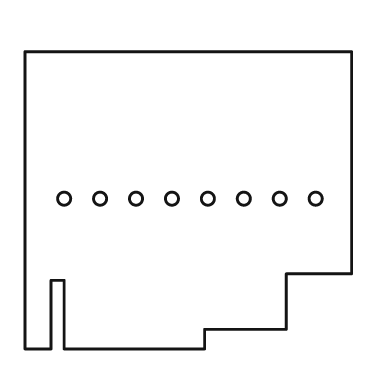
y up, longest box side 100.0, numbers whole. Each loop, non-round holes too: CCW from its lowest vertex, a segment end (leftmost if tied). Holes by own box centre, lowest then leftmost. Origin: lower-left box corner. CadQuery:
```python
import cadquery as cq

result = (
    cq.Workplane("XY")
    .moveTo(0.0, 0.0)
    .lineTo(8.0, 0.0)
    .lineTo(8.0, 21.0)
    .lineTo(12.0, 21.0)
    .lineTo(12.0, 0.0)
    .lineTo(55.0, 0.0)
    .lineTo(55.0, 6.0)
    .lineTo(80.0, 6.0)
    .lineTo(80.0, 23.0)
    .lineTo(100.0, 23.0)
    .lineTo(100.0, 91.0)
    .lineTo(0.0, 91.0)
    .close()
    .moveTo(12.0, 46.0)
    .circle(2.0)
    .moveTo(23.0, 46.0)
    .circle(2.0)
    .moveTo(34.0, 46.0)
    .circle(2.0)
    .moveTo(45.0, 46.0)
    .circle(2.0)
    .moveTo(56.0, 46.0)
    .circle(2.0)
    .moveTo(67.0, 46.0)
    .circle(2.0)
    .moveTo(78.0, 46.0)
    .circle(2.0)
    .moveTo(89.0, 46.0)
    .circle(2.0)
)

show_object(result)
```